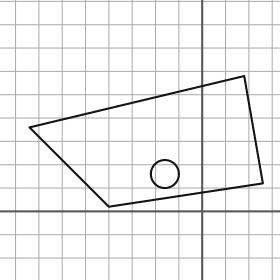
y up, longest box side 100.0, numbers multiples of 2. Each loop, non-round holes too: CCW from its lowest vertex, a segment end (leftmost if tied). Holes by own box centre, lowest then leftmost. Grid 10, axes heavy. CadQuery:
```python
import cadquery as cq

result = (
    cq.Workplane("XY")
    .moveTo(-40.0, 2.0)
    .lineTo(26.0, 12.0)
    .lineTo(18.0, 58.0)
    .lineTo(-74.0, 36.0)
    .close()
    .moveTo(-16.0, 16.0)
    .circle(6.0)
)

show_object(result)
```